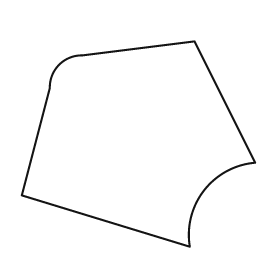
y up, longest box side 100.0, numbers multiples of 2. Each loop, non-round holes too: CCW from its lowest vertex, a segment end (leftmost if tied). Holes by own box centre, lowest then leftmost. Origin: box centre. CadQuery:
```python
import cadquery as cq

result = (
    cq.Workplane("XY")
    .moveTo(22.0, -44.0)
    .threePointArc((28.0, -20.0), (50.0, -8.0))
    .lineTo(24.0, 44.0)
    .lineTo(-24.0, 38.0)
    .threePointArc((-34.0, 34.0), (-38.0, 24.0))
    .lineTo(-50.0, -22.0)
    .close()
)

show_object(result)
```